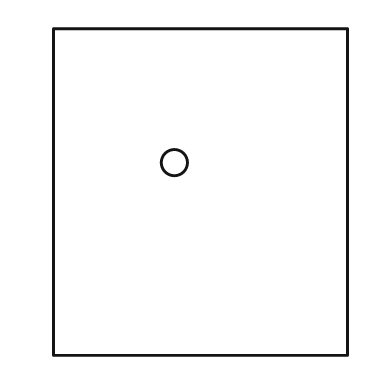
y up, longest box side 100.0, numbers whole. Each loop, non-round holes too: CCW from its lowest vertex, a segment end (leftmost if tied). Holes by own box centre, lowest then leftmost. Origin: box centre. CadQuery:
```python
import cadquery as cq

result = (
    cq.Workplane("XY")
    .moveTo(-45.0, -50.0)
    .lineTo(45.0, -50.0)
    .lineTo(45.0, 50.0)
    .lineTo(-45.0, 50.0)
    .close()
    .moveTo(-8.0, 9.0)
    .circle(4.0)
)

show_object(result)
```